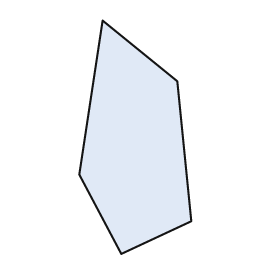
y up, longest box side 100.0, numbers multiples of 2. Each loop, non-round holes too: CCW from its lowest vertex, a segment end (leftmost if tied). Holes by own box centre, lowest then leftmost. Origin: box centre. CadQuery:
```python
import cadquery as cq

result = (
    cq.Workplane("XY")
    .moveTo(-6.0, -50.0)
    .lineTo(24.0, -36.0)
    .lineTo(18.0, 24.0)
    .lineTo(-14.0, 50.0)
    .lineTo(-24.0, -16.0)
    .close()
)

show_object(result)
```